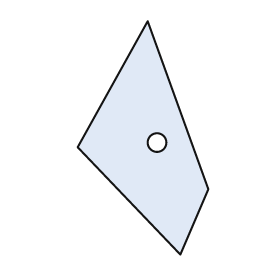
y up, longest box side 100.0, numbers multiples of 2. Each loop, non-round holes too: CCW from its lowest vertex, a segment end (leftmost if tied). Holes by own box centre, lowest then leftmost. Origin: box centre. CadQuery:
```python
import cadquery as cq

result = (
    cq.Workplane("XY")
    .moveTo(16.0, -50.0)
    .lineTo(28.0, -22.0)
    .lineTo(2.0, 50.0)
    .lineTo(-28.0, -4.0)
    .close()
    .moveTo(6.0, -2.0)
    .circle(4.0)
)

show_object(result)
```